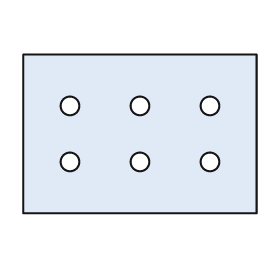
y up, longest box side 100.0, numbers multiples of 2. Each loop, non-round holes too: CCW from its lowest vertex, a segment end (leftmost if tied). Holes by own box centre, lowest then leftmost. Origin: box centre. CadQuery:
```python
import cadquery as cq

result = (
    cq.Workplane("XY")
    .moveTo(-50.0, -34.0)
    .lineTo(50.0, -34.0)
    .lineTo(50.0, 34.0)
    .lineTo(-50.0, 34.0)
    .close()
    .moveTo(-30.0, -12.0)
    .circle(4.0)
    .moveTo(0.0, -12.0)
    .circle(4.0)
    .moveTo(30.0, -12.0)
    .circle(4.0)
    .moveTo(-30.0, 12.0)
    .circle(4.0)
    .moveTo(0.0, 12.0)
    .circle(4.0)
    .moveTo(30.0, 12.0)
    .circle(4.0)
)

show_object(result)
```